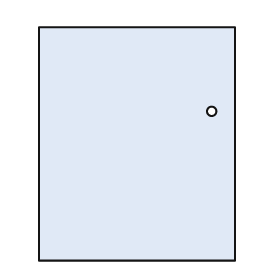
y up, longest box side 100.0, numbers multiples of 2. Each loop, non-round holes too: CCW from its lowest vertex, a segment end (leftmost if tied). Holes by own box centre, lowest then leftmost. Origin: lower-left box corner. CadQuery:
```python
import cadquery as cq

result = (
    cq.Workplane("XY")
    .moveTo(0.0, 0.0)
    .lineTo(84.0, 0.0)
    .lineTo(84.0, 100.0)
    .lineTo(0.0, 100.0)
    .close()
    .moveTo(74.0, 64.0)
    .circle(2.0)
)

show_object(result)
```